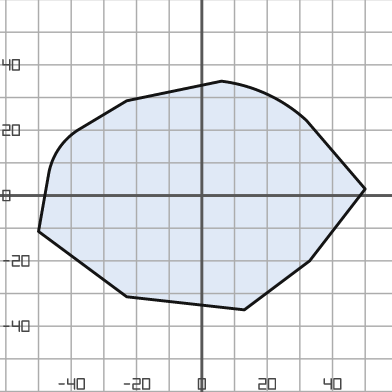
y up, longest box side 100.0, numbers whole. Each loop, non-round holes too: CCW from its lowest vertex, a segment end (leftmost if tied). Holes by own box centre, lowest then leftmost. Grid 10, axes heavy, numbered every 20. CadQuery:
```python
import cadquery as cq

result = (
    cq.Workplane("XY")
    .moveTo(13.0, -35.0)
    .lineTo(33.0, -20.0)
    .lineTo(50.0, 2.0)
    .lineTo(32.0, 23.0)
    .threePointArc((20.0, 31.0), (6.0, 35.0))
    .lineTo(-23.0, 29.0)
    .lineTo(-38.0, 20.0)
    .threePointArc((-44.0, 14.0), (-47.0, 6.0))
    .lineTo(-50.0, -11.0)
    .lineTo(-23.0, -31.0)
    .close()
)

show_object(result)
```